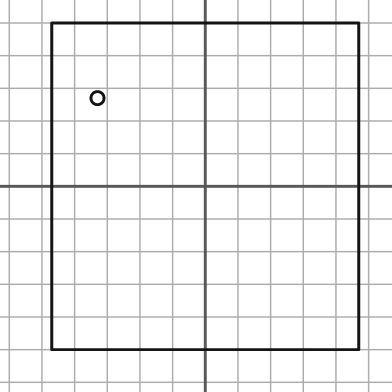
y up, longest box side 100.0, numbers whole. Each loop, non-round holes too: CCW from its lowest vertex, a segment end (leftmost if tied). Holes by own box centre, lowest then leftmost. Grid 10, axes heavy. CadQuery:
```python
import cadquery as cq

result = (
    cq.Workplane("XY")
    .moveTo(-47.0, -50.0)
    .lineTo(47.0, -50.0)
    .lineTo(47.0, 50.0)
    .lineTo(-47.0, 50.0)
    .close()
    .moveTo(-33.0, 27.0)
    .circle(2.0)
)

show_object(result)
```